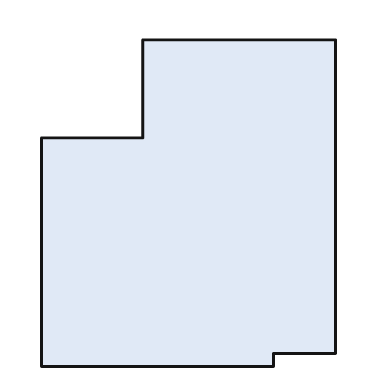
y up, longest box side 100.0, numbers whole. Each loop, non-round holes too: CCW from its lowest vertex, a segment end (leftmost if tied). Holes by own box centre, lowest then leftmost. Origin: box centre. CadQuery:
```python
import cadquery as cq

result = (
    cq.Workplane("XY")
    .moveTo(-45.0, -50.0)
    .lineTo(26.0, -50.0)
    .lineTo(26.0, -46.0)
    .lineTo(45.0, -46.0)
    .lineTo(45.0, 50.0)
    .lineTo(-14.0, 50.0)
    .lineTo(-14.0, 20.0)
    .lineTo(-45.0, 20.0)
    .close()
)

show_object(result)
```